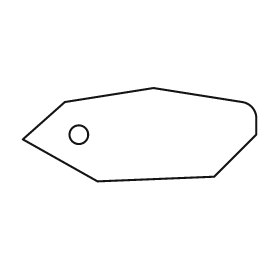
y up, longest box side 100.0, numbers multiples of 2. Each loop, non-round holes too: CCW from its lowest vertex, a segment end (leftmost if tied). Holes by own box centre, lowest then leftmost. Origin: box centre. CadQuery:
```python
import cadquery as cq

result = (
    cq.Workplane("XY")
    .moveTo(-18.0, -20.0)
    .lineTo(32.0, -18.0)
    .lineTo(50.0, 0.0)
    .lineTo(50.0, 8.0)
    .threePointArc((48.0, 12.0), (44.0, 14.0))
    .lineTo(6.0, 20.0)
    .lineTo(-32.0, 14.0)
    .lineTo(-50.0, -2.0)
    .close()
    .moveTo(-26.0, 0.0)
    .circle(4.0)
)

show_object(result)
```